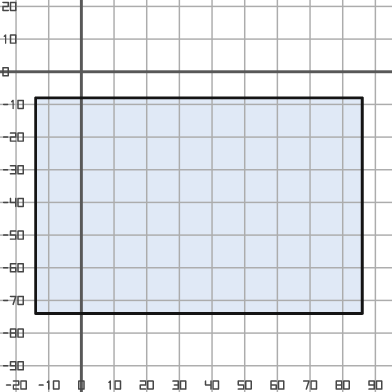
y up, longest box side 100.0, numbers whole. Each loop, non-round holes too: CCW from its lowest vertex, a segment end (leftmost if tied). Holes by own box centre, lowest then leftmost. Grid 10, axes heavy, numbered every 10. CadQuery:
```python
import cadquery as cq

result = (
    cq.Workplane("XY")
    .moveTo(-14.0, -74.0)
    .lineTo(86.0, -74.0)
    .lineTo(86.0, -8.0)
    .lineTo(-14.0, -8.0)
    .close()
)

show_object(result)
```